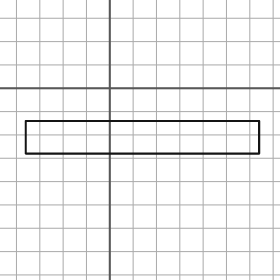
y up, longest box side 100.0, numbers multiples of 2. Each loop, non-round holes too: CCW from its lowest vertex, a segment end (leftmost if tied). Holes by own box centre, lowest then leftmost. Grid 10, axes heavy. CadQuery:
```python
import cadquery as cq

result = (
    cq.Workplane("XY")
    .moveTo(-36.0, -28.0)
    .lineTo(64.0, -28.0)
    .lineTo(64.0, -14.0)
    .lineTo(-36.0, -14.0)
    .close()
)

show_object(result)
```